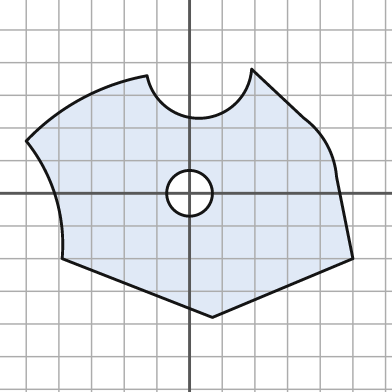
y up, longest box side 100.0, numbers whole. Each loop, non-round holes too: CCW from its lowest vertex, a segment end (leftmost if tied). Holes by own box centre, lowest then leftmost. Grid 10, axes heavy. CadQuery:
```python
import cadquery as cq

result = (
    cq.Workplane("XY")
    .moveTo(7.0, -38.0)
    .lineTo(50.0, -20.0)
    .lineTo(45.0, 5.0)
    .threePointArc((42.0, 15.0), (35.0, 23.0))
    .lineTo(19.0, 38.0)
    .threePointArc((4.0, 23.0), (-13.0, 36.0))
    .threePointArc((-33.0, 29.0), (-50.0, 16.0))
    .threePointArc((-41.0, -1.0), (-39.0, -20.0))
    .close()
    .moveTo(0.0, 0.0)
    .circle(7.0)
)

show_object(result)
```